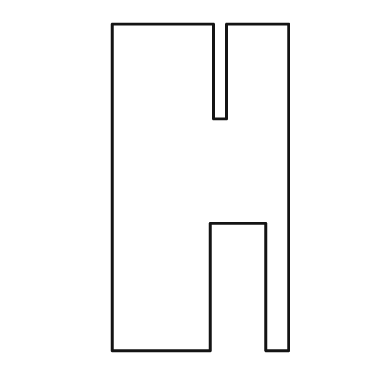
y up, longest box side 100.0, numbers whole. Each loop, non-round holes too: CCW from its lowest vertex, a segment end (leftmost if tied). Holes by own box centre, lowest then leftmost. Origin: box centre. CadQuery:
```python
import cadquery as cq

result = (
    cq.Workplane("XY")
    .moveTo(-27.0, -50.0)
    .lineTo(3.0, -50.0)
    .lineTo(3.0, -11.0)
    .lineTo(20.0, -11.0)
    .lineTo(20.0, -50.0)
    .lineTo(27.0, -50.0)
    .lineTo(27.0, 50.0)
    .lineTo(8.0, 50.0)
    .lineTo(8.0, 21.0)
    .lineTo(4.0, 21.0)
    .lineTo(4.0, 50.0)
    .lineTo(-27.0, 50.0)
    .close()
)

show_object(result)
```